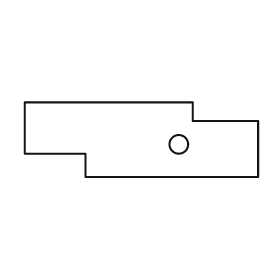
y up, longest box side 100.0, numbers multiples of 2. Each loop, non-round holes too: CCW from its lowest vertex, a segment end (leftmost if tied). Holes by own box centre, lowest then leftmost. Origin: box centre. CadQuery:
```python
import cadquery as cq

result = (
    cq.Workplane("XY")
    .moveTo(-24.0, -16.0)
    .lineTo(50.0, -16.0)
    .lineTo(50.0, 8.0)
    .lineTo(22.0, 8.0)
    .lineTo(22.0, 16.0)
    .lineTo(-50.0, 16.0)
    .lineTo(-50.0, -6.0)
    .lineTo(-24.0, -6.0)
    .close()
    .moveTo(16.0, -2.0)
    .circle(4.0)
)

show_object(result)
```